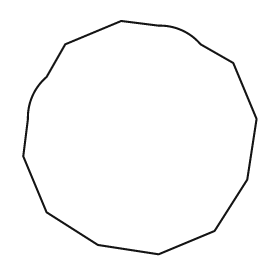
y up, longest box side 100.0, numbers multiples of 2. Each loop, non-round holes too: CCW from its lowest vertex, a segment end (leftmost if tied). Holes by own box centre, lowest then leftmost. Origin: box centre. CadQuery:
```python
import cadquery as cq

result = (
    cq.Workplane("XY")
    .moveTo(8.0, -50.0)
    .lineTo(32.0, -40.0)
    .lineTo(46.0, -18.0)
    .lineTo(50.0, 8.0)
    .lineTo(40.0, 32.0)
    .lineTo(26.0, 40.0)
    .threePointArc((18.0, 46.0), (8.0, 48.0))
    .lineTo(-8.0, 50.0)
    .lineTo(-32.0, 40.0)
    .lineTo(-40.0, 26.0)
    .threePointArc((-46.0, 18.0), (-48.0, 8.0))
    .lineTo(-50.0, -8.0)
    .lineTo(-40.0, -32.0)
    .lineTo(-18.0, -46.0)
    .close()
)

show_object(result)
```